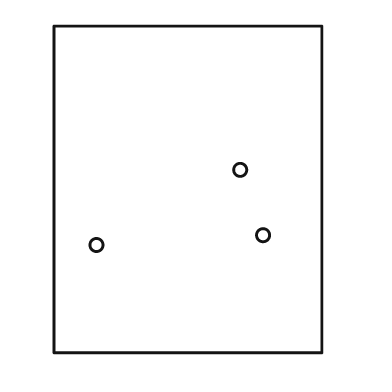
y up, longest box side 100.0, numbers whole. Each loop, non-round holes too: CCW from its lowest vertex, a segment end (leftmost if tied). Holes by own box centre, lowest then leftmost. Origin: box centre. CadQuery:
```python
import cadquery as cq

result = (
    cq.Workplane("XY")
    .moveTo(-41.0, -50.0)
    .lineTo(41.0, -50.0)
    .lineTo(41.0, 50.0)
    .lineTo(-41.0, 50.0)
    .close()
    .moveTo(-28.0, -17.0)
    .circle(2.0)
    .moveTo(23.0, -14.0)
    .circle(2.0)
    .moveTo(16.0, 6.0)
    .circle(2.0)
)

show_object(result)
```